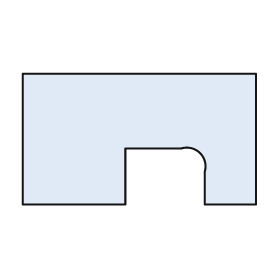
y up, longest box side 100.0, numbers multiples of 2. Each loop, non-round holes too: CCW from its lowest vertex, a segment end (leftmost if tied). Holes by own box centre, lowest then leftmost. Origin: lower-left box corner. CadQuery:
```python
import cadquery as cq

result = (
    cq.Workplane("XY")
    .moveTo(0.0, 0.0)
    .lineTo(44.0, 0.0)
    .lineTo(44.0, 24.0)
    .lineTo(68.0, 24.0)
    .threePointArc((76.0, 22.0), (78.0, 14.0))
    .lineTo(78.0, 0.0)
    .lineTo(100.0, 0.0)
    .lineTo(100.0, 56.0)
    .lineTo(0.0, 56.0)
    .close()
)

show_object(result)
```